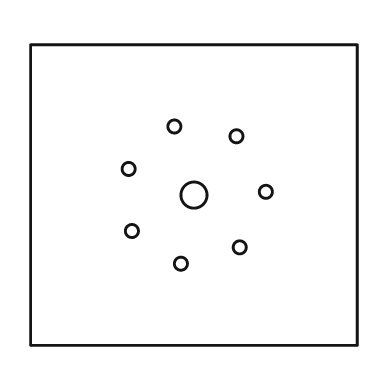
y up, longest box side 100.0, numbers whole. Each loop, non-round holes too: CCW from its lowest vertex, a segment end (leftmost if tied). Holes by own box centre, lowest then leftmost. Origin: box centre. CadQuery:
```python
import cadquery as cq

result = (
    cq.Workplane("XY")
    .moveTo(-50.0, -46.0)
    .lineTo(50.0, -46.0)
    .lineTo(50.0, 46.0)
    .lineTo(-50.0, 46.0)
    .close()
    .moveTo(-4.0, -21.0)
    .circle(2.0)
    .moveTo(14.0, -16.0)
    .circle(2.0)
    .moveTo(-19.0, -11.0)
    .circle(2.0)
    .moveTo(0.0, 0.0)
    .circle(4.0)
    .moveTo(22.0, 1.0)
    .circle(2.0)
    .moveTo(-20.0, 8.0)
    .circle(2.0)
    .moveTo(13.0, 18.0)
    .circle(2.0)
    .moveTo(-6.0, 21.0)
    .circle(2.0)
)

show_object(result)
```